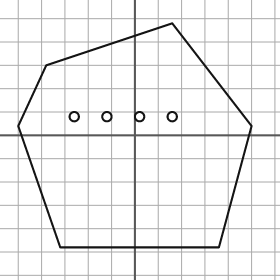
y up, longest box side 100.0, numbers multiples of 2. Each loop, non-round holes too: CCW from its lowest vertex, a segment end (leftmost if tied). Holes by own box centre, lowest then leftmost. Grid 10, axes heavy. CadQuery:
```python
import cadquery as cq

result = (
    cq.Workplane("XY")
    .moveTo(-32.0, -48.0)
    .lineTo(36.0, -48.0)
    .lineTo(50.0, 4.0)
    .lineTo(16.0, 48.0)
    .lineTo(-38.0, 30.0)
    .lineTo(-50.0, 4.0)
    .close()
    .moveTo(-26.0, 8.0)
    .circle(2.0)
    .moveTo(-12.0, 8.0)
    .circle(2.0)
    .moveTo(2.0, 8.0)
    .circle(2.0)
    .moveTo(16.0, 8.0)
    .circle(2.0)
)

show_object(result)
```